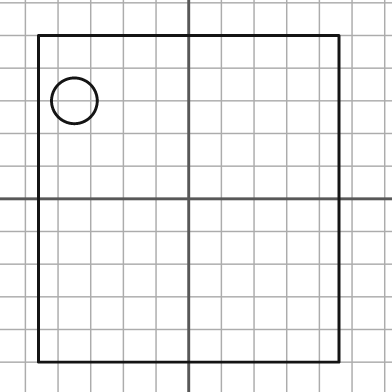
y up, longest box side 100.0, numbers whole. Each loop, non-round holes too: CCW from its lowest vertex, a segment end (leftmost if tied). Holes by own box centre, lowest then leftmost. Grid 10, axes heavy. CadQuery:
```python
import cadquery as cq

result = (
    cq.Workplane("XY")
    .moveTo(-46.0, -50.0)
    .lineTo(46.0, -50.0)
    .lineTo(46.0, 50.0)
    .lineTo(-46.0, 50.0)
    .close()
    .moveTo(-35.0, 30.0)
    .circle(7.0)
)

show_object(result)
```